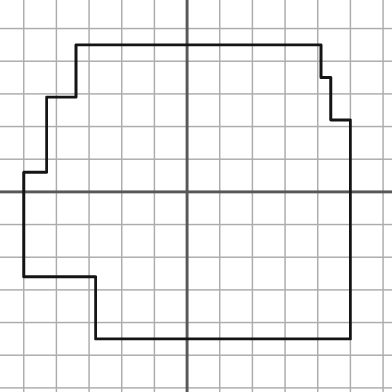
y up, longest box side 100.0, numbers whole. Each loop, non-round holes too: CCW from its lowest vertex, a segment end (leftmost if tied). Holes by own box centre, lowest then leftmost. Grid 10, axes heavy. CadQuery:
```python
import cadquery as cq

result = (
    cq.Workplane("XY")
    .moveTo(-28.0, -45.0)
    .lineTo(50.0, -45.0)
    .lineTo(50.0, 22.0)
    .lineTo(44.0, 22.0)
    .lineTo(44.0, 35.0)
    .lineTo(41.0, 35.0)
    .lineTo(41.0, 45.0)
    .lineTo(-34.0, 45.0)
    .lineTo(-34.0, 29.0)
    .lineTo(-43.0, 29.0)
    .lineTo(-43.0, 6.0)
    .lineTo(-50.0, 6.0)
    .lineTo(-50.0, -26.0)
    .lineTo(-28.0, -26.0)
    .close()
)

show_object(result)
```